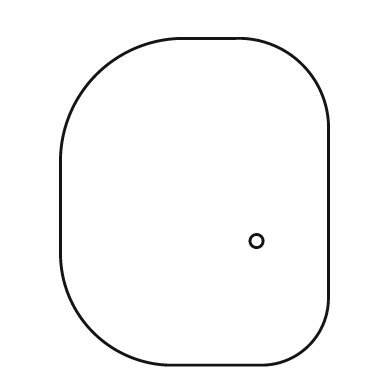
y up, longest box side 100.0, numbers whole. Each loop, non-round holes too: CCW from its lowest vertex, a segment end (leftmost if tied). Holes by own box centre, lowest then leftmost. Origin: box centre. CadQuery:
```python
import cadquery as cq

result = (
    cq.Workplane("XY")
    .moveTo(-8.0, -50.0)
    .lineTo(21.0, -50.0)
    .threePointArc((35.0, -44.0), (41.0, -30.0))
    .lineTo(41.0, 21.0)
    .threePointArc((33.0, 42.0), (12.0, 50.0))
    .lineTo(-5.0, 50.0)
    .threePointArc((-30.0, 39.0), (-41.0, 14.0))
    .lineTo(-41.0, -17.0)
    .threePointArc((-31.0, -40.0), (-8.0, -50.0))
    .close()
    .moveTo(19.0, -12.0)
    .circle(2.0)
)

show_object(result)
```